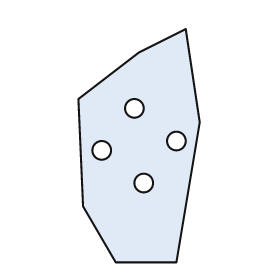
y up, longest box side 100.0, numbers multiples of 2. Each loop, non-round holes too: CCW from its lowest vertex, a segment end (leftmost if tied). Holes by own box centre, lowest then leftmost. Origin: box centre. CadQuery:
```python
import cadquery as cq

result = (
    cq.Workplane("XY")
    .moveTo(-10.0, -50.0)
    .lineTo(16.0, -50.0)
    .lineTo(26.0, 10.0)
    .lineTo(20.0, 50.0)
    .lineTo(0.0, 40.0)
    .lineTo(-26.0, 20.0)
    .lineTo(-24.0, -26.0)
    .close()
    .moveTo(2.0, -16.0)
    .circle(4.0)
    .moveTo(-16.0, -2.0)
    .circle(4.0)
    .moveTo(16.0, 2.0)
    .circle(4.0)
    .moveTo(-2.0, 16.0)
    .circle(4.0)
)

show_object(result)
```